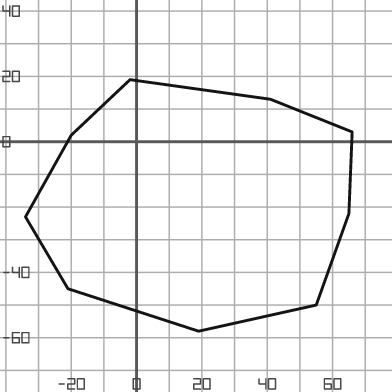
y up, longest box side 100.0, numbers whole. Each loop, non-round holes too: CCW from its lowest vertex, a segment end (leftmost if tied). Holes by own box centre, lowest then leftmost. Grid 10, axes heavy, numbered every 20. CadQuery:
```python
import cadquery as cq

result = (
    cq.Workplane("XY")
    .moveTo(19.0, -58.0)
    .lineTo(55.0, -50.0)
    .lineTo(65.0, -22.0)
    .lineTo(66.0, 3.0)
    .lineTo(41.0, 13.0)
    .lineTo(-2.0, 19.0)
    .lineTo(-20.0, 2.0)
    .lineTo(-34.0, -23.0)
    .lineTo(-21.0, -45.0)
    .close()
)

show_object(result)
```